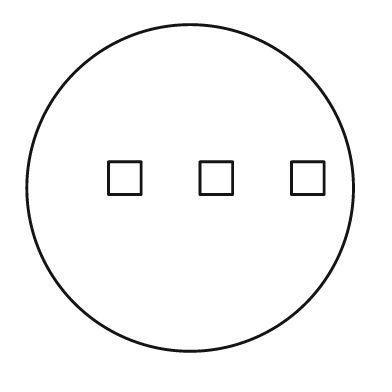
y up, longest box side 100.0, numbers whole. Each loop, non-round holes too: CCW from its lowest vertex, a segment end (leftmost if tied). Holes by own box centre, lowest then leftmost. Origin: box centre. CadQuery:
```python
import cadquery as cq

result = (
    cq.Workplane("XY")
    .moveTo(0.0, 0.0)
    .circle(50.0)
    .moveTo(-25.0, -2.0)
    .lineTo(-15.0, -2.0)
    .lineTo(-15.0, 8.0)
    .lineTo(-25.0, 8.0)
    .close()
    .moveTo(3.0, -2.0)
    .lineTo(13.0, -2.0)
    .lineTo(13.0, 8.0)
    .lineTo(3.0, 8.0)
    .close()
    .moveTo(31.0, -2.0)
    .lineTo(41.0, -2.0)
    .lineTo(41.0, 8.0)
    .lineTo(31.0, 8.0)
    .close()
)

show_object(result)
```